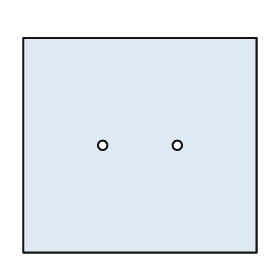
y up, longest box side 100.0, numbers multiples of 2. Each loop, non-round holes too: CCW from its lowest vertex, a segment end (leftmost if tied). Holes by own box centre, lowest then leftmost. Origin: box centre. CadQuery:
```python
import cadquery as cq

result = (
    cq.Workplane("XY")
    .moveTo(-50.0, -46.0)
    .lineTo(50.0, -46.0)
    .lineTo(50.0, 46.0)
    .lineTo(-50.0, 46.0)
    .close()
    .moveTo(-16.0, 0.0)
    .circle(2.0)
    .moveTo(16.0, 0.0)
    .circle(2.0)
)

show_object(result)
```